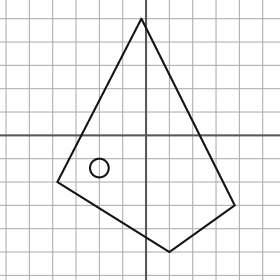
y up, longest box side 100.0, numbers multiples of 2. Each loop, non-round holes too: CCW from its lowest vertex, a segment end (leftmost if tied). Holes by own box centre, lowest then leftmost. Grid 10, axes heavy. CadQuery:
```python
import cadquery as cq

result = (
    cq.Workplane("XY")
    .moveTo(10.0, -50.0)
    .lineTo(38.0, -30.0)
    .lineTo(-2.0, 50.0)
    .lineTo(-38.0, -20.0)
    .close()
    .moveTo(-20.0, -14.0)
    .circle(4.0)
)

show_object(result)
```